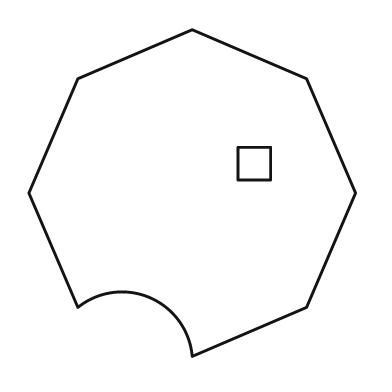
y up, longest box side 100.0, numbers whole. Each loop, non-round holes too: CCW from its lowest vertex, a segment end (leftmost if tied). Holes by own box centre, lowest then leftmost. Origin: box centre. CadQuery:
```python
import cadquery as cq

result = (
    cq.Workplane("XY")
    .moveTo(0.0, -50.0)
    .lineTo(35.0, -35.0)
    .lineTo(50.0, 0.0)
    .lineTo(35.0, 35.0)
    .lineTo(0.0, 50.0)
    .lineTo(-35.0, 35.0)
    .lineTo(-50.0, 0.0)
    .lineTo(-35.0, -35.0)
    .threePointArc((-13.0, -32.0), (0.0, -50.0))
    .close()
    .moveTo(14.0, 4.0)
    .lineTo(24.0, 4.0)
    .lineTo(24.0, 14.0)
    .lineTo(14.0, 14.0)
    .close()
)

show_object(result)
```